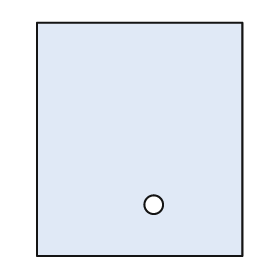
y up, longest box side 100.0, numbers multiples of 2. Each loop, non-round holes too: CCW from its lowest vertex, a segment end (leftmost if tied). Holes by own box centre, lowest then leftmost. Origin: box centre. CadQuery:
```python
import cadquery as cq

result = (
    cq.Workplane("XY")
    .moveTo(-44.0, -50.0)
    .lineTo(44.0, -50.0)
    .lineTo(44.0, 50.0)
    .lineTo(-44.0, 50.0)
    .close()
    .moveTo(6.0, -28.0)
    .circle(4.0)
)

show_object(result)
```